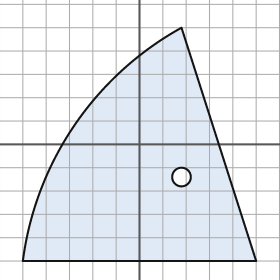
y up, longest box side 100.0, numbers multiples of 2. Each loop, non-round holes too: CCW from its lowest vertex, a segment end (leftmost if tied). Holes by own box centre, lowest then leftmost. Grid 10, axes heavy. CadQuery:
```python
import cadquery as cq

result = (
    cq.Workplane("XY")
    .moveTo(-50.0, -50.0)
    .lineTo(50.0, -50.0)
    .lineTo(18.0, 50.0)
    .threePointArc((-28.0, 8.0), (-50.0, -50.0))
    .close()
    .moveTo(18.0, -14.0)
    .circle(4.0)
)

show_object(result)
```